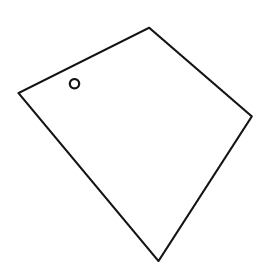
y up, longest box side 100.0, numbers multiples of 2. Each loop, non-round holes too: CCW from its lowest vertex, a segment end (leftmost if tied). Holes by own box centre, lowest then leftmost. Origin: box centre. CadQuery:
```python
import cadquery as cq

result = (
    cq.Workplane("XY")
    .moveTo(10.0, -50.0)
    .lineTo(50.0, 12.0)
    .lineTo(6.0, 50.0)
    .lineTo(-50.0, 22.0)
    .close()
    .moveTo(-26.0, 26.0)
    .circle(2.0)
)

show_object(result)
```